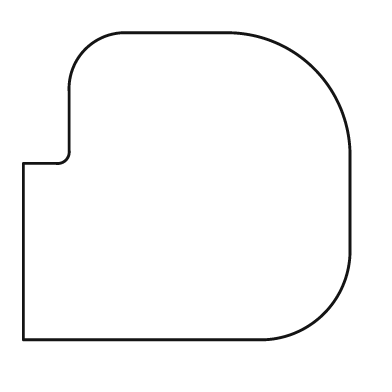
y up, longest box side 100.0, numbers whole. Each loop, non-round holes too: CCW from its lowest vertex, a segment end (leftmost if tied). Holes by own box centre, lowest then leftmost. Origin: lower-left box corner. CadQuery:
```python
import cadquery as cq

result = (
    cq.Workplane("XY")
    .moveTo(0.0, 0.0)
    .lineTo(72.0, 0.0)
    .threePointArc((92.0, 8.0), (100.0, 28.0))
    .lineTo(100.0, 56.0)
    .threePointArc((89.0, 83.0), (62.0, 94.0))
    .lineTo(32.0, 94.0)
    .threePointArc((19.0, 89.0), (14.0, 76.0))
    .lineTo(14.0, 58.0)
    .threePointArc((13.0, 55.0), (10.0, 54.0))
    .lineTo(0.0, 54.0)
    .close()
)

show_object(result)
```